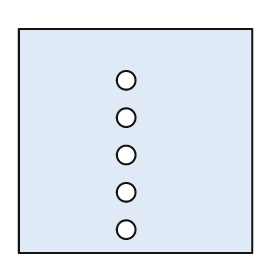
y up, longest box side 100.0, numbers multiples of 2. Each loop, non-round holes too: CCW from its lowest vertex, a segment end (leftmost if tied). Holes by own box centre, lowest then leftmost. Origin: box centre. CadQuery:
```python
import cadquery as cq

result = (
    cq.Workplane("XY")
    .moveTo(-50.0, -48.0)
    .lineTo(50.0, -48.0)
    .lineTo(50.0, 48.0)
    .lineTo(-50.0, 48.0)
    .close()
    .moveTo(-4.0, -38.0)
    .circle(4.0)
    .moveTo(-4.0, -22.0)
    .circle(4.0)
    .moveTo(-4.0, -6.0)
    .circle(4.0)
    .moveTo(-4.0, 10.0)
    .circle(4.0)
    .moveTo(-4.0, 26.0)
    .circle(4.0)
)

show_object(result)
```